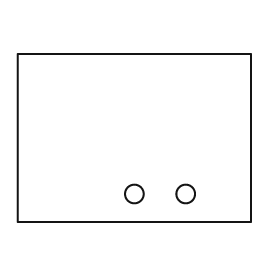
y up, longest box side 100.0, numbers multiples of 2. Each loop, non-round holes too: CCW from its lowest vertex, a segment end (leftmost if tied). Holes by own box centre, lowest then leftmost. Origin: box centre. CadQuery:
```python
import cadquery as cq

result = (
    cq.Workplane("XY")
    .moveTo(-50.0, -36.0)
    .lineTo(50.0, -36.0)
    .lineTo(50.0, 36.0)
    .lineTo(-50.0, 36.0)
    .close()
    .moveTo(0.0, -24.0)
    .circle(4.0)
    .moveTo(22.0, -24.0)
    .circle(4.0)
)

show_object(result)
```